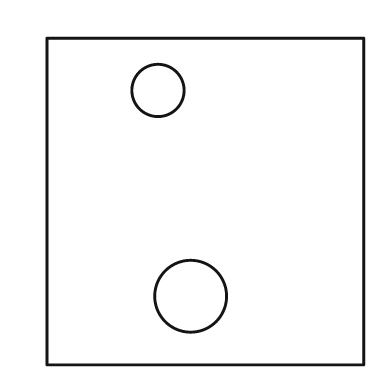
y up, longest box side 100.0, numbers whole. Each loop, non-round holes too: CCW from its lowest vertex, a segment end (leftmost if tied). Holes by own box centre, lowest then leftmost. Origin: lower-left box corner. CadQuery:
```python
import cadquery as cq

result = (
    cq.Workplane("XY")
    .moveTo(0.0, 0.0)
    .lineTo(97.0, 0.0)
    .lineTo(97.0, 100.0)
    .lineTo(0.0, 100.0)
    .close()
    .moveTo(44.0, 21.0)
    .circle(11.0)
    .moveTo(34.0, 84.0)
    .circle(8.0)
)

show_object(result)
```